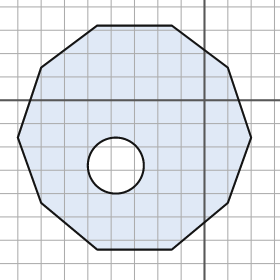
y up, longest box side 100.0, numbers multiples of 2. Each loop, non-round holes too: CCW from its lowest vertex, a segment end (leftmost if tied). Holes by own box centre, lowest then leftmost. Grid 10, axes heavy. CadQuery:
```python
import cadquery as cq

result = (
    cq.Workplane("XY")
    .moveTo(-46.0, -64.0)
    .lineTo(-14.0, -64.0)
    .lineTo(10.0, -44.0)
    .lineTo(20.0, -16.0)
    .lineTo(10.0, 14.0)
    .lineTo(-14.0, 32.0)
    .lineTo(-46.0, 32.0)
    .lineTo(-70.0, 14.0)
    .lineTo(-80.0, -16.0)
    .lineTo(-70.0, -44.0)
    .close()
    .moveTo(-38.0, -28.0)
    .circle(12.0)
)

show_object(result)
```